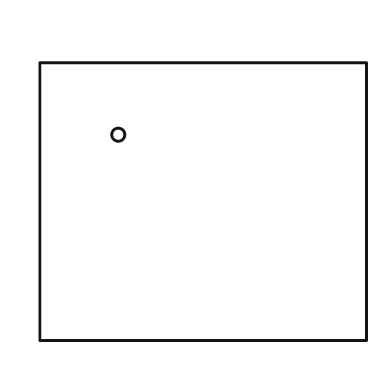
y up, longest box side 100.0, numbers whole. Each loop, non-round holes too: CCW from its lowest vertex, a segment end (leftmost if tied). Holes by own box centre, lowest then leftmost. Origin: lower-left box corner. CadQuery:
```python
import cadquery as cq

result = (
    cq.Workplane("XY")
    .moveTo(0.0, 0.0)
    .lineTo(100.0, 0.0)
    .lineTo(100.0, 85.0)
    .lineTo(0.0, 85.0)
    .close()
    .moveTo(24.0, 63.0)
    .circle(2.0)
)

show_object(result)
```